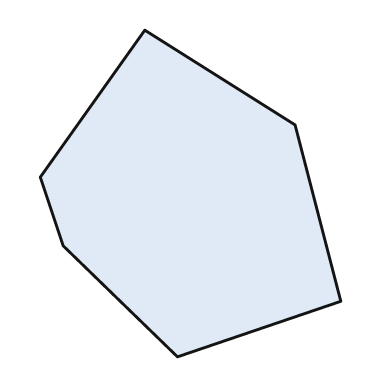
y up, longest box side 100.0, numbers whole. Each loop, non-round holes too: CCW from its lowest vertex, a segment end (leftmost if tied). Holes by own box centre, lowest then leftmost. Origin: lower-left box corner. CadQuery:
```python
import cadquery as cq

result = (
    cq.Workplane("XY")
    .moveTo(42.0, 0.0)
    .lineTo(92.0, 17.0)
    .lineTo(78.0, 71.0)
    .lineTo(32.0, 100.0)
    .lineTo(0.0, 55.0)
    .lineTo(7.0, 34.0)
    .close()
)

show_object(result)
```